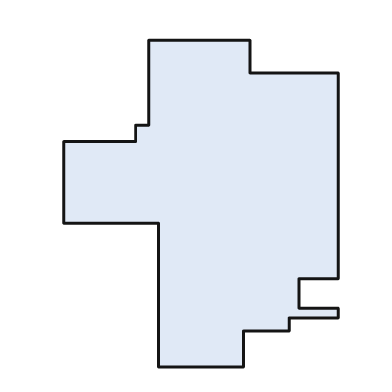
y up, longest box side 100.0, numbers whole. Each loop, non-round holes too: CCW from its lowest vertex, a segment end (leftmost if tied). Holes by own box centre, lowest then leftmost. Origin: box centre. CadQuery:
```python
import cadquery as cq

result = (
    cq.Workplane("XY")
    .moveTo(-13.0, -50.0)
    .lineTo(13.0, -50.0)
    .lineTo(13.0, -39.0)
    .lineTo(27.0, -39.0)
    .lineTo(27.0, -35.0)
    .lineTo(42.0, -35.0)
    .lineTo(42.0, -32.0)
    .lineTo(30.0, -32.0)
    .lineTo(30.0, -23.0)
    .lineTo(42.0, -23.0)
    .lineTo(42.0, 40.0)
    .lineTo(15.0, 40.0)
    .lineTo(15.0, 50.0)
    .lineTo(-16.0, 50.0)
    .lineTo(-16.0, 24.0)
    .lineTo(-20.0, 24.0)
    .lineTo(-20.0, 19.0)
    .lineTo(-42.0, 19.0)
    .lineTo(-42.0, -6.0)
    .lineTo(-13.0, -6.0)
    .close()
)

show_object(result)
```